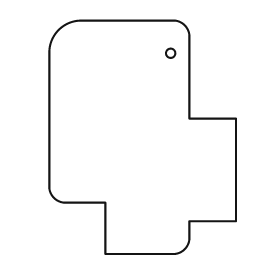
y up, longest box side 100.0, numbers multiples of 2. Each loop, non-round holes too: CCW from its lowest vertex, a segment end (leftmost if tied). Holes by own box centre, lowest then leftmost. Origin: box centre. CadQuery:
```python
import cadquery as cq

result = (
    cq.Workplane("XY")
    .moveTo(-16.0, -50.0)
    .lineTo(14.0, -50.0)
    .threePointArc((18.0, -48.0), (20.0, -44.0))
    .lineTo(20.0, -36.0)
    .lineTo(40.0, -36.0)
    .lineTo(40.0, 8.0)
    .lineTo(20.0, 8.0)
    .lineTo(20.0, 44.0)
    .threePointArc((18.0, 48.0), (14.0, 50.0))
    .lineTo(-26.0, 50.0)
    .threePointArc((-36.0, 46.0), (-40.0, 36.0))
    .lineTo(-40.0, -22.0)
    .threePointArc((-38.0, -26.0), (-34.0, -28.0))
    .lineTo(-16.0, -28.0)
    .close()
    .moveTo(12.0, 36.0)
    .circle(2.0)
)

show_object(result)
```